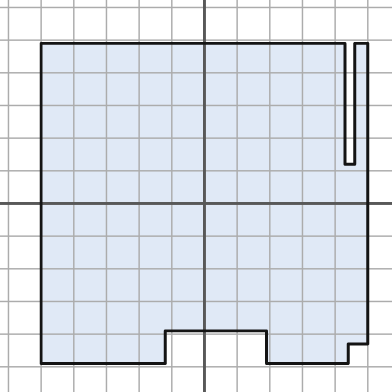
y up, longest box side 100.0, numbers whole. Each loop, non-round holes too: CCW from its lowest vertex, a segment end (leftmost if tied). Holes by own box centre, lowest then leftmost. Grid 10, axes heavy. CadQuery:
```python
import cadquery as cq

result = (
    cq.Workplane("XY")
    .moveTo(-50.0, -49.0)
    .lineTo(-12.0, -49.0)
    .lineTo(-12.0, -39.0)
    .lineTo(19.0, -39.0)
    .lineTo(19.0, -49.0)
    .lineTo(44.0, -49.0)
    .lineTo(44.0, -43.0)
    .lineTo(50.0, -43.0)
    .lineTo(50.0, 49.0)
    .lineTo(46.0, 49.0)
    .lineTo(46.0, 12.0)
    .lineTo(43.0, 12.0)
    .lineTo(43.0, 49.0)
    .lineTo(-50.0, 49.0)
    .close()
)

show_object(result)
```